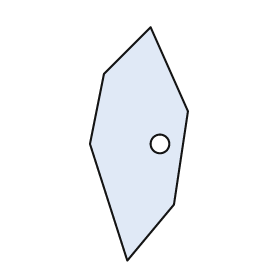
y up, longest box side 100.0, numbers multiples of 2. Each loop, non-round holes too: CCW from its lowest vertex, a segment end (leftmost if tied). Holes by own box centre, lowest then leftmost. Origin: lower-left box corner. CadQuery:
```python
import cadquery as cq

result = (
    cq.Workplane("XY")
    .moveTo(16.0, 0.0)
    .lineTo(36.0, 24.0)
    .lineTo(42.0, 64.0)
    .lineTo(26.0, 100.0)
    .lineTo(6.0, 80.0)
    .lineTo(0.0, 50.0)
    .close()
    .moveTo(30.0, 50.0)
    .circle(4.0)
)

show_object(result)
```